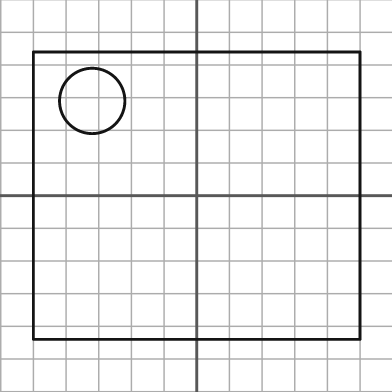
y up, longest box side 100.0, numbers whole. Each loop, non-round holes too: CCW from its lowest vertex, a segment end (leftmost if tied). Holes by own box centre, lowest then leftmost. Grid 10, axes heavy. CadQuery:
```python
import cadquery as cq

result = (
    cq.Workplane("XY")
    .moveTo(-50.0, -44.0)
    .lineTo(50.0, -44.0)
    .lineTo(50.0, 44.0)
    .lineTo(-50.0, 44.0)
    .close()
    .moveTo(-32.0, 29.0)
    .circle(10.0)
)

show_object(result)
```